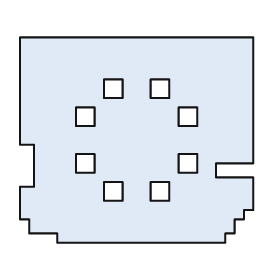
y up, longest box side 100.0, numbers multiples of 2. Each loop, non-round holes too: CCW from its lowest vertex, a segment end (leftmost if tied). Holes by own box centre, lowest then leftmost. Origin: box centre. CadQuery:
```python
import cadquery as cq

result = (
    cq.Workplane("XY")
    .moveTo(-34.0, -44.0)
    .lineTo(38.0, -44.0)
    .lineTo(38.0, -40.0)
    .lineTo(42.0, -40.0)
    .lineTo(42.0, -34.0)
    .lineTo(46.0, -34.0)
    .lineTo(46.0, -30.0)
    .lineTo(50.0, -30.0)
    .lineTo(50.0, -16.0)
    .lineTo(34.0, -16.0)
    .lineTo(34.0, -10.0)
    .lineTo(50.0, -10.0)
    .lineTo(50.0, 44.0)
    .lineTo(-50.0, 44.0)
    .lineTo(-50.0, -2.0)
    .lineTo(-44.0, -2.0)
    .lineTo(-44.0, -20.0)
    .lineTo(-50.0, -20.0)
    .lineTo(-50.0, -34.0)
    .lineTo(-46.0, -34.0)
    .lineTo(-46.0, -40.0)
    .lineTo(-34.0, -40.0)
    .close()
    .moveTo(-14.0, -26.0)
    .lineTo(-6.0, -26.0)
    .lineTo(-6.0, -18.0)
    .lineTo(-14.0, -18.0)
    .close()
    .moveTo(6.0, -26.0)
    .lineTo(14.0, -26.0)
    .lineTo(14.0, -18.0)
    .lineTo(6.0, -18.0)
    .close()
    .moveTo(-26.0, -14.0)
    .lineTo(-18.0, -14.0)
    .lineTo(-18.0, -6.0)
    .lineTo(-26.0, -6.0)
    .close()
    .moveTo(18.0, -14.0)
    .lineTo(26.0, -14.0)
    .lineTo(26.0, -6.0)
    .lineTo(18.0, -6.0)
    .close()
    .moveTo(-26.0, 6.0)
    .lineTo(-18.0, 6.0)
    .lineTo(-18.0, 14.0)
    .lineTo(-26.0, 14.0)
    .close()
    .moveTo(18.0, 6.0)
    .lineTo(26.0, 6.0)
    .lineTo(26.0, 14.0)
    .lineTo(18.0, 14.0)
    .close()
    .moveTo(-14.0, 18.0)
    .lineTo(-6.0, 18.0)
    .lineTo(-6.0, 26.0)
    .lineTo(-14.0, 26.0)
    .close()
    .moveTo(6.0, 18.0)
    .lineTo(14.0, 18.0)
    .lineTo(14.0, 26.0)
    .lineTo(6.0, 26.0)
    .close()
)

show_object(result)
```